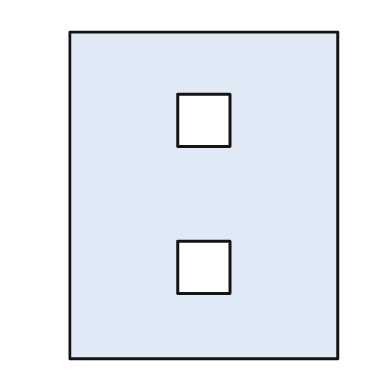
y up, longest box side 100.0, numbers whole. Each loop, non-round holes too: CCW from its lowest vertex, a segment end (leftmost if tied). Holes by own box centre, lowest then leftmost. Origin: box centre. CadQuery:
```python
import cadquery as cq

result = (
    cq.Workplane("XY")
    .moveTo(-41.0, -50.0)
    .lineTo(41.0, -50.0)
    .lineTo(41.0, 50.0)
    .lineTo(-41.0, 50.0)
    .close()
    .moveTo(-8.0, -30.0)
    .lineTo(8.0, -30.0)
    .lineTo(8.0, -14.0)
    .lineTo(-8.0, -14.0)
    .close()
    .moveTo(-8.0, 15.0)
    .lineTo(8.0, 15.0)
    .lineTo(8.0, 31.0)
    .lineTo(-8.0, 31.0)
    .close()
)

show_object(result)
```